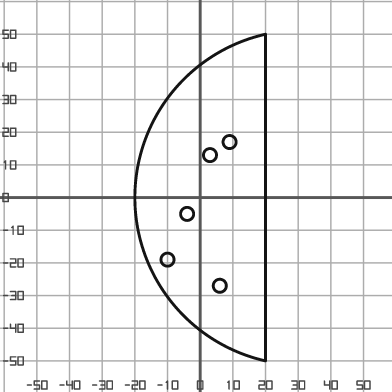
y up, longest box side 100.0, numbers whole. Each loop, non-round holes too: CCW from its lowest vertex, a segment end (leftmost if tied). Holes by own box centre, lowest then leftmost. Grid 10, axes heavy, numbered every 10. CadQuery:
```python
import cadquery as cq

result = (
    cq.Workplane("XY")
    .moveTo(20.0, -50.0)
    .lineTo(20.0, 50.0)
    .threePointArc((-20.0, 0.0), (20.0, -50.0))
    .close()
    .moveTo(6.0, -27.0)
    .circle(2.0)
    .moveTo(-10.0, -19.0)
    .circle(2.0)
    .moveTo(-4.0, -5.0)
    .circle(2.0)
    .moveTo(3.0, 13.0)
    .circle(2.0)
    .moveTo(9.0, 17.0)
    .circle(2.0)
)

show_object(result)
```